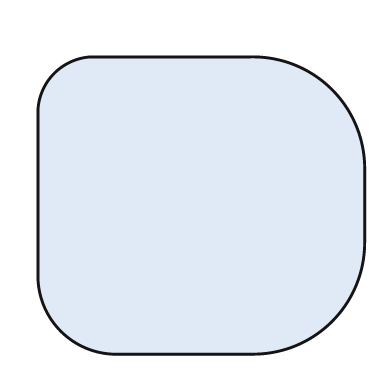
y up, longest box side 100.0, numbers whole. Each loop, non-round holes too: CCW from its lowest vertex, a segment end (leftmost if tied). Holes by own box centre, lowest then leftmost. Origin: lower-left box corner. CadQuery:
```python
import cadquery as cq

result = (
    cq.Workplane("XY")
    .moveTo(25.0, 0.0)
    .lineTo(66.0, 0.0)
    .threePointArc((90.0, 10.0), (100.0, 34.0))
    .lineTo(100.0, 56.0)
    .threePointArc((90.0, 81.0), (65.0, 91.0))
    .lineTo(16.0, 91.0)
    .threePointArc((5.0, 86.0), (0.0, 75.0))
    .lineTo(0.0, 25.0)
    .threePointArc((7.0, 7.0), (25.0, 0.0))
    .close()
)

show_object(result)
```